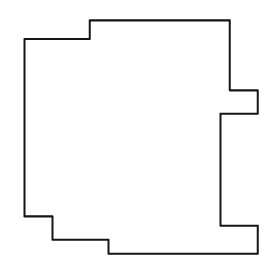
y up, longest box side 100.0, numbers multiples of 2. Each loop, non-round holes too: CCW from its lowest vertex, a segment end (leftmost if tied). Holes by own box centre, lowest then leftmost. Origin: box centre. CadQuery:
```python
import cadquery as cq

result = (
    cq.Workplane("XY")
    .moveTo(-14.0, -50.0)
    .lineTo(50.0, -50.0)
    .lineTo(50.0, -38.0)
    .lineTo(34.0, -38.0)
    .lineTo(34.0, 10.0)
    .lineTo(50.0, 10.0)
    .lineTo(50.0, 20.0)
    .lineTo(38.0, 20.0)
    .lineTo(38.0, 50.0)
    .lineTo(-22.0, 50.0)
    .lineTo(-22.0, 42.0)
    .lineTo(-50.0, 42.0)
    .lineTo(-50.0, -34.0)
    .lineTo(-38.0, -34.0)
    .lineTo(-38.0, -44.0)
    .lineTo(-14.0, -44.0)
    .close()
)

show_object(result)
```